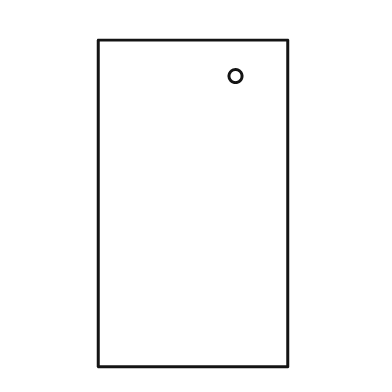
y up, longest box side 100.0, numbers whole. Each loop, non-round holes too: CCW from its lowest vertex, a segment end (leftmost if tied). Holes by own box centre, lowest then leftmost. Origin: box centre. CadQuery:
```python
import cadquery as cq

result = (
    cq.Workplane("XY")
    .moveTo(-29.0, -50.0)
    .lineTo(29.0, -50.0)
    .lineTo(29.0, 50.0)
    .lineTo(-29.0, 50.0)
    .close()
    .moveTo(13.0, 39.0)
    .circle(2.0)
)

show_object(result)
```